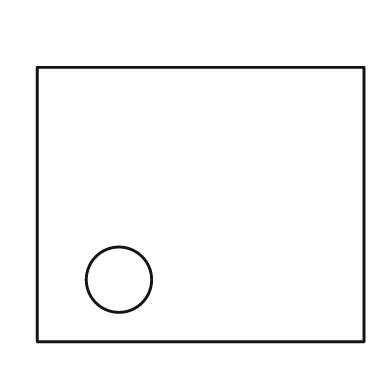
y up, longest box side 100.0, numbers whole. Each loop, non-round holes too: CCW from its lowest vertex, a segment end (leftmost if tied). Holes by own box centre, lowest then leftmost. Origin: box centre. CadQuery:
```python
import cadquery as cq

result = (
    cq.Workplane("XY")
    .moveTo(-50.0, -42.0)
    .lineTo(50.0, -42.0)
    .lineTo(50.0, 42.0)
    .lineTo(-50.0, 42.0)
    .close()
    .moveTo(-25.0, -23.0)
    .circle(10.0)
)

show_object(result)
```